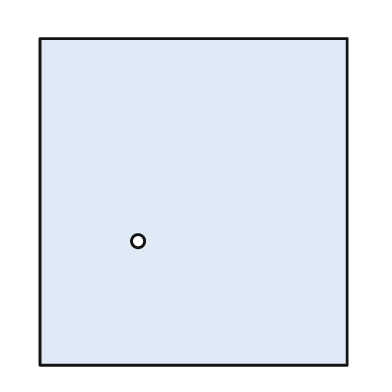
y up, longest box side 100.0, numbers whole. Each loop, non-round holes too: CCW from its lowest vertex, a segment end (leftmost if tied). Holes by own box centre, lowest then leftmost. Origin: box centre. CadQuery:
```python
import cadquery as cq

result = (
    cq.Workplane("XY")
    .moveTo(-47.0, -50.0)
    .lineTo(47.0, -50.0)
    .lineTo(47.0, 50.0)
    .lineTo(-47.0, 50.0)
    .close()
    .moveTo(-17.0, -12.0)
    .circle(2.0)
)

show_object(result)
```